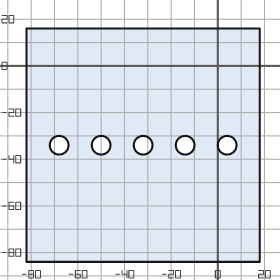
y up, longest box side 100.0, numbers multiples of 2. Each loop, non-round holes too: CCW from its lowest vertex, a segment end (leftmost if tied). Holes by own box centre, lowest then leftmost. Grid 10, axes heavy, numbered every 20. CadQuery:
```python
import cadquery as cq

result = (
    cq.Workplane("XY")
    .moveTo(-82.0, -84.0)
    .lineTo(18.0, -84.0)
    .lineTo(18.0, 16.0)
    .lineTo(-82.0, 16.0)
    .close()
    .moveTo(-68.0, -34.0)
    .circle(4.0)
    .moveTo(-50.0, -34.0)
    .circle(4.0)
    .moveTo(-32.0, -34.0)
    .circle(4.0)
    .moveTo(-14.0, -34.0)
    .circle(4.0)
    .moveTo(4.0, -34.0)
    .circle(4.0)
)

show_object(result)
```